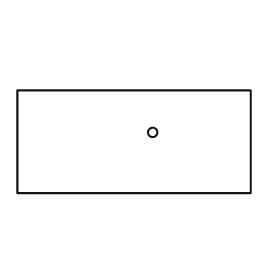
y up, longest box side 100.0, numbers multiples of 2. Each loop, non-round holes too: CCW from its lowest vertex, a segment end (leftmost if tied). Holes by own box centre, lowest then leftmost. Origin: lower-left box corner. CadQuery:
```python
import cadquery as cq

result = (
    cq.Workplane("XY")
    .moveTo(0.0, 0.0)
    .lineTo(100.0, 0.0)
    .lineTo(100.0, 44.0)
    .lineTo(0.0, 44.0)
    .close()
    .moveTo(58.0, 26.0)
    .circle(2.0)
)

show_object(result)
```